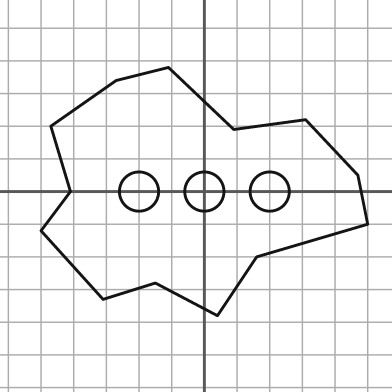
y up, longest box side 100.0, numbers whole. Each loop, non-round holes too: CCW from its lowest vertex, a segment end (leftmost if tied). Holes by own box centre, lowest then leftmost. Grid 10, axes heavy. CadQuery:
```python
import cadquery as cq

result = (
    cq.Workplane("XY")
    .moveTo(4.0, -38.0)
    .lineTo(16.0, -20.0)
    .lineTo(50.0, -10.0)
    .lineTo(47.0, 5.0)
    .lineTo(31.0, 22.0)
    .lineTo(9.0, 19.0)
    .lineTo(-11.0, 38.0)
    .lineTo(-27.0, 34.0)
    .lineTo(-47.0, 20.0)
    .lineTo(-41.0, 0.0)
    .lineTo(-50.0, -12.0)
    .lineTo(-31.0, -33.0)
    .lineTo(-15.0, -28.0)
    .close()
    .moveTo(-20.0, 0.0)
    .circle(6.0)
    .moveTo(0.0, 0.0)
    .circle(6.0)
    .moveTo(20.0, 0.0)
    .circle(6.0)
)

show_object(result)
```